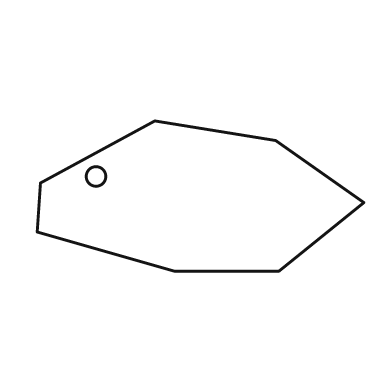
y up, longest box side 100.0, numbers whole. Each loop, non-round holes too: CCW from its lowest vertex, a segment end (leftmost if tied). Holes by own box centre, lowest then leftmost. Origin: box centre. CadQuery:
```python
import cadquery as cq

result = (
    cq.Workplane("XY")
    .moveTo(-8.0, -23.0)
    .lineTo(24.0, -23.0)
    .lineTo(50.0, -2.0)
    .lineTo(23.0, 17.0)
    .lineTo(-14.0, 23.0)
    .lineTo(-49.0, 4.0)
    .lineTo(-50.0, -11.0)
    .close()
    .moveTo(-32.0, 6.0)
    .circle(3.0)
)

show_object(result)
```